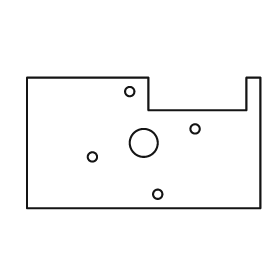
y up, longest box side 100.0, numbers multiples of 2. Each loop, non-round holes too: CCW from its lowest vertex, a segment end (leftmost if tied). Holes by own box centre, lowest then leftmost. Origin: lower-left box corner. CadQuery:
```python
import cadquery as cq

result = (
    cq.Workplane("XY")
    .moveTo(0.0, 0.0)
    .lineTo(100.0, 0.0)
    .lineTo(100.0, 56.0)
    .lineTo(94.0, 56.0)
    .lineTo(94.0, 42.0)
    .lineTo(52.0, 42.0)
    .lineTo(52.0, 56.0)
    .lineTo(0.0, 56.0)
    .close()
    .moveTo(56.0, 6.0)
    .circle(2.0)
    .moveTo(28.0, 22.0)
    .circle(2.0)
    .moveTo(50.0, 28.0)
    .circle(6.0)
    .moveTo(72.0, 34.0)
    .circle(2.0)
    .moveTo(44.0, 50.0)
    .circle(2.0)
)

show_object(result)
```